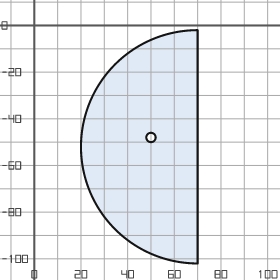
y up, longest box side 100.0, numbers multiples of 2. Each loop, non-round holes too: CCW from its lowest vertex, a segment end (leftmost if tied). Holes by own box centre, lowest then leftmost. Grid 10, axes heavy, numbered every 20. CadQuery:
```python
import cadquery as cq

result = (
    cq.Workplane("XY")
    .moveTo(70.0, -102.0)
    .lineTo(70.0, -2.0)
    .threePointArc((20.0, -52.0), (70.0, -102.0))
    .close()
    .moveTo(50.0, -48.0)
    .circle(2.0)
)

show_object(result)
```